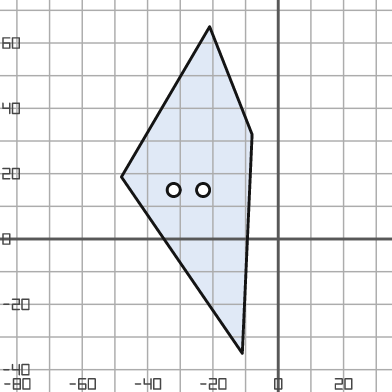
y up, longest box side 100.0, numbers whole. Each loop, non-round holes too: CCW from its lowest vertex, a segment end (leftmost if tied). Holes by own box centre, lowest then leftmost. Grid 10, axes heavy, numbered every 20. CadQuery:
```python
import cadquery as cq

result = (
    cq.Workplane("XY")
    .moveTo(-11.0, -35.0)
    .lineTo(-8.0, 32.0)
    .lineTo(-21.0, 65.0)
    .lineTo(-48.0, 19.0)
    .close()
    .moveTo(-32.0, 15.0)
    .circle(2.0)
    .moveTo(-23.0, 15.0)
    .circle(2.0)
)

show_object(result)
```